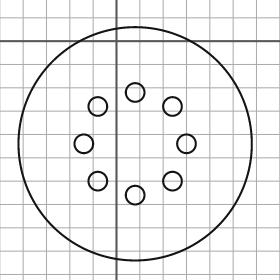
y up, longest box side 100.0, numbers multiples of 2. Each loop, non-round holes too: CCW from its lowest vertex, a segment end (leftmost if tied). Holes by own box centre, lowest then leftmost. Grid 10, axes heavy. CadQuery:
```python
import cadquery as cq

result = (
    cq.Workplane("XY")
    .moveTo(8.0, -44.0)
    .circle(50.0)
    .moveTo(8.0, -66.0)
    .circle(4.0)
    .moveTo(-8.0, -60.0)
    .circle(4.0)
    .moveTo(24.0, -60.0)
    .circle(4.0)
    .moveTo(-14.0, -44.0)
    .circle(4.0)
    .moveTo(30.0, -44.0)
    .circle(4.0)
    .moveTo(-8.0, -28.0)
    .circle(4.0)
    .moveTo(24.0, -28.0)
    .circle(4.0)
    .moveTo(8.0, -22.0)
    .circle(4.0)
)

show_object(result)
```